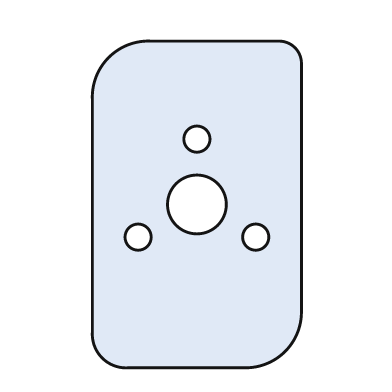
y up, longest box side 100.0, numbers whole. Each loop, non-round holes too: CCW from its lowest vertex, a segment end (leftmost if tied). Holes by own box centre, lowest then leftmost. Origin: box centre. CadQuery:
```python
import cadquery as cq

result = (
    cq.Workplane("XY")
    .moveTo(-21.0, -50.0)
    .lineTo(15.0, -50.0)
    .threePointArc((27.0, -45.0), (32.0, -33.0))
    .lineTo(32.0, 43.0)
    .threePointArc((30.0, 48.0), (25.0, 50.0))
    .lineTo(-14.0, 50.0)
    .threePointArc((-27.0, 45.0), (-32.0, 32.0))
    .lineTo(-32.0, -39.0)
    .threePointArc((-29.0, -47.0), (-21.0, -50.0))
    .close()
    .moveTo(-18.0, -10.0)
    .circle(4.0)
    .moveTo(18.0, -10.0)
    .circle(4.0)
    .moveTo(0.0, 0.0)
    .circle(9.0)
    .moveTo(0.0, 20.0)
    .circle(4.0)
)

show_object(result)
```